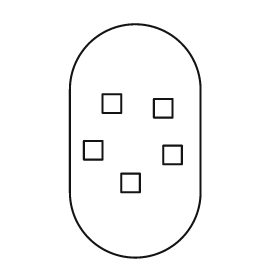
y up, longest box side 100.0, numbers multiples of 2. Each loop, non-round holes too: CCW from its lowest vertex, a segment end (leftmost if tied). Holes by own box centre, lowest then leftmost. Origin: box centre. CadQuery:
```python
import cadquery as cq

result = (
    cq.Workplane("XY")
    .moveTo(-28.0, -22.0)
    .threePointArc((0.0, -50.0), (28.0, -22.0))
    .lineTo(28.0, 22.0)
    .threePointArc((0.0, 50.0), (-28.0, 22.0))
    .close()
    .moveTo(-6.0, -22.0)
    .lineTo(2.0, -22.0)
    .lineTo(2.0, -14.0)
    .lineTo(-6.0, -14.0)
    .close()
    .moveTo(12.0, -10.0)
    .lineTo(20.0, -10.0)
    .lineTo(20.0, -2.0)
    .lineTo(12.0, -2.0)
    .close()
    .moveTo(-22.0, -8.0)
    .lineTo(-14.0, -8.0)
    .lineTo(-14.0, 0.0)
    .lineTo(-22.0, 0.0)
    .close()
    .moveTo(8.0, 10.0)
    .lineTo(16.0, 10.0)
    .lineTo(16.0, 18.0)
    .lineTo(8.0, 18.0)
    .close()
    .moveTo(-14.0, 12.0)
    .lineTo(-6.0, 12.0)
    .lineTo(-6.0, 20.0)
    .lineTo(-14.0, 20.0)
    .close()
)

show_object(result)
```